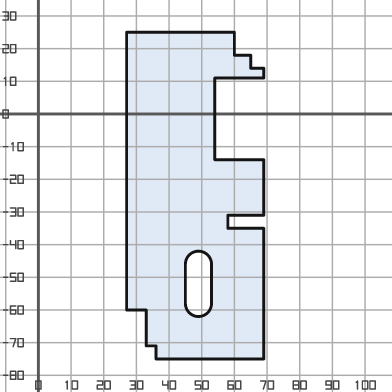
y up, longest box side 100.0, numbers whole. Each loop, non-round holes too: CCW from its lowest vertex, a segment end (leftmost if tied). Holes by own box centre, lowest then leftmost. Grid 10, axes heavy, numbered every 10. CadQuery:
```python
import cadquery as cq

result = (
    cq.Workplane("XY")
    .moveTo(36.0, -75.0)
    .lineTo(69.0, -75.0)
    .lineTo(69.0, -35.0)
    .lineTo(58.0, -35.0)
    .lineTo(58.0, -31.0)
    .lineTo(69.0, -31.0)
    .lineTo(69.0, -14.0)
    .lineTo(54.0, -14.0)
    .lineTo(54.0, 11.0)
    .lineTo(69.0, 11.0)
    .lineTo(69.0, 14.0)
    .lineTo(65.0, 14.0)
    .lineTo(65.0, 18.0)
    .lineTo(60.0, 18.0)
    .lineTo(60.0, 25.0)
    .lineTo(27.0, 25.0)
    .lineTo(27.0, -60.0)
    .lineTo(33.0, -60.0)
    .lineTo(33.0, -71.0)
    .lineTo(36.0, -71.0)
    .close()
    .moveTo(45.0, -58.0)
    .threePointArc((49.0, -62.0), (53.0, -58.0))
    .lineTo(53.0, -46.0)
    .threePointArc((49.0, -42.0), (45.0, -46.0))
    .close()
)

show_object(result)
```